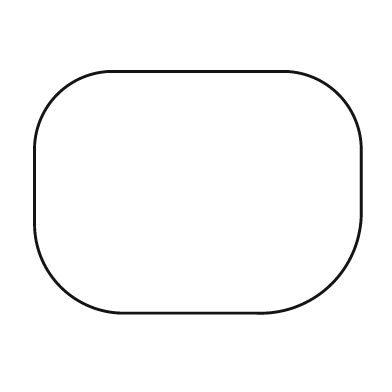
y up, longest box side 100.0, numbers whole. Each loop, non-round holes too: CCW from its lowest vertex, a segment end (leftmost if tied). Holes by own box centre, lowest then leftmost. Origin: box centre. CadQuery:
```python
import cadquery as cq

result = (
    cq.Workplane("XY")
    .moveTo(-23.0, -37.0)
    .lineTo(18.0, -37.0)
    .threePointArc((41.0, -28.0), (50.0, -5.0))
    .lineTo(50.0, 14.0)
    .threePointArc((43.0, 30.0), (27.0, 37.0))
    .lineTo(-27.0, 37.0)
    .threePointArc((-43.0, 30.0), (-50.0, 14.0))
    .lineTo(-50.0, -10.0)
    .threePointArc((-42.0, -29.0), (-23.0, -37.0))
    .close()
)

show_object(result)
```